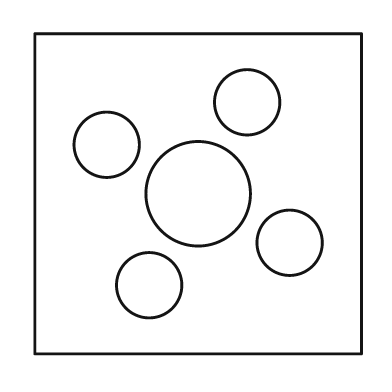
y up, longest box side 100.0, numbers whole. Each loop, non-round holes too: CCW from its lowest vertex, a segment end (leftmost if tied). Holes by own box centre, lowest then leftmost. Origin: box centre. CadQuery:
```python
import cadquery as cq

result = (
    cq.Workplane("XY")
    .moveTo(-50.0, -49.0)
    .lineTo(50.0, -49.0)
    .lineTo(50.0, 49.0)
    .lineTo(-50.0, 49.0)
    .close()
    .moveTo(-15.0, -28.0)
    .circle(10.0)
    .moveTo(28.0, -15.0)
    .circle(10.0)
    .moveTo(0.0, 0.0)
    .circle(16.0)
    .moveTo(-28.0, 15.0)
    .circle(10.0)
    .moveTo(15.0, 28.0)
    .circle(10.0)
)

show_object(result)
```